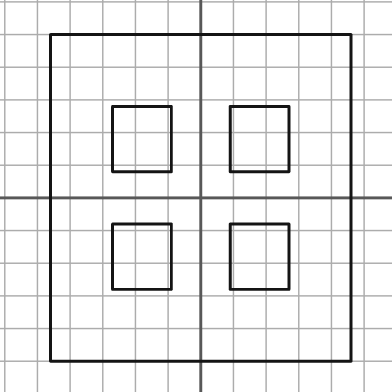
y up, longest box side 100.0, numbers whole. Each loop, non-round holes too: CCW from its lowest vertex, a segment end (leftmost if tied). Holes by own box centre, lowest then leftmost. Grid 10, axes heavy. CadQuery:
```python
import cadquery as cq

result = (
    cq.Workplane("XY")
    .moveTo(-46.0, -50.0)
    .lineTo(46.0, -50.0)
    .lineTo(46.0, 50.0)
    .lineTo(-46.0, 50.0)
    .close()
    .moveTo(-27.0, -28.0)
    .lineTo(-9.0, -28.0)
    .lineTo(-9.0, -8.0)
    .lineTo(-27.0, -8.0)
    .close()
    .moveTo(9.0, -28.0)
    .lineTo(27.0, -28.0)
    .lineTo(27.0, -8.0)
    .lineTo(9.0, -8.0)
    .close()
    .moveTo(-27.0, 8.0)
    .lineTo(-9.0, 8.0)
    .lineTo(-9.0, 28.0)
    .lineTo(-27.0, 28.0)
    .close()
    .moveTo(9.0, 8.0)
    .lineTo(27.0, 8.0)
    .lineTo(27.0, 28.0)
    .lineTo(9.0, 28.0)
    .close()
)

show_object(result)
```